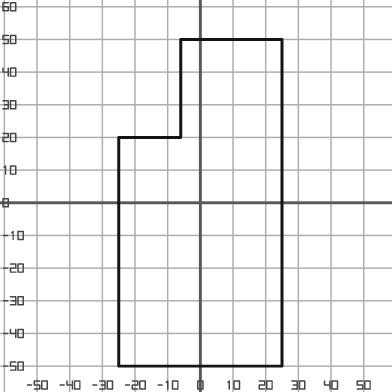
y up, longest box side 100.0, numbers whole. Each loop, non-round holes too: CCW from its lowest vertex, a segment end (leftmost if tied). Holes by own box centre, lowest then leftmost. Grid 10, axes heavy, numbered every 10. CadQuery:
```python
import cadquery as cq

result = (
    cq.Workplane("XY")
    .moveTo(-25.0, -50.0)
    .lineTo(25.0, -50.0)
    .lineTo(25.0, 50.0)
    .lineTo(-6.0, 50.0)
    .lineTo(-6.0, 20.0)
    .lineTo(-25.0, 20.0)
    .close()
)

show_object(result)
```